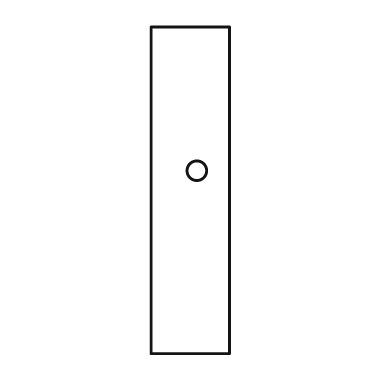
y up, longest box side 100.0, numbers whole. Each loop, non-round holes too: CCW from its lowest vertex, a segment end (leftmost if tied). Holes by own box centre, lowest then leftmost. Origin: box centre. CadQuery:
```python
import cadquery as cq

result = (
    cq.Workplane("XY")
    .moveTo(-12.0, -50.0)
    .lineTo(12.0, -50.0)
    .lineTo(12.0, 50.0)
    .lineTo(-12.0, 50.0)
    .close()
    .moveTo(2.0, 6.0)
    .circle(3.0)
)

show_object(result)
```